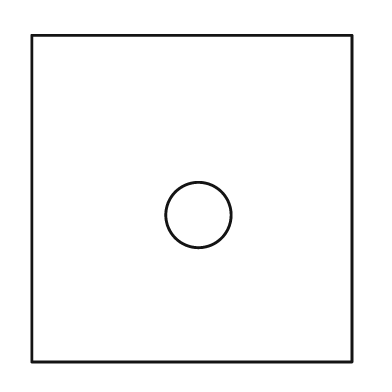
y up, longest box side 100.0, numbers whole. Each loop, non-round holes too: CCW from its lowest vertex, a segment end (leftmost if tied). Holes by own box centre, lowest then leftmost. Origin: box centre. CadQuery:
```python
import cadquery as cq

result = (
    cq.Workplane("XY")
    .moveTo(-49.0, -50.0)
    .lineTo(49.0, -50.0)
    .lineTo(49.0, 50.0)
    .lineTo(-49.0, 50.0)
    .close()
    .moveTo(2.0, -5.0)
    .circle(10.0)
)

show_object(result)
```